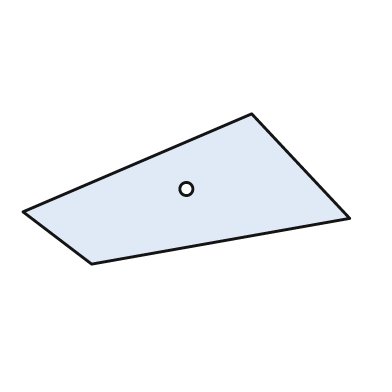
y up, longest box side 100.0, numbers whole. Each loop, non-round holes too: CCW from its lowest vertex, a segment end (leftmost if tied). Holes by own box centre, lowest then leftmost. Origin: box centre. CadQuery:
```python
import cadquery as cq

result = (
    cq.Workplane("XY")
    .moveTo(-29.0, -23.0)
    .lineTo(50.0, -9.0)
    .lineTo(20.0, 23.0)
    .lineTo(-50.0, -7.0)
    .close()
    .moveTo(0.0, 0.0)
    .circle(2.0)
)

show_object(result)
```